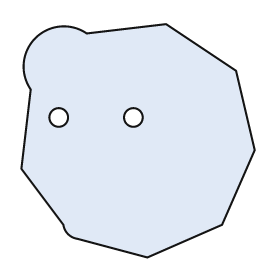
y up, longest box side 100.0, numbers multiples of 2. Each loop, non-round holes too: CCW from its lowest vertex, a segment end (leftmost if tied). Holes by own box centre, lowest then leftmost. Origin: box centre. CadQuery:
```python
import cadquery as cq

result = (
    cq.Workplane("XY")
    .moveTo(4.0, -50.0)
    .lineTo(36.0, -36.0)
    .lineTo(50.0, -4.0)
    .lineTo(42.0, 30.0)
    .lineTo(12.0, 50.0)
    .lineTo(-22.0, 46.0)
    .threePointArc((-44.0, 44.0), (-46.0, 22.0))
    .lineTo(-50.0, -12.0)
    .lineTo(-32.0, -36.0)
    .threePointArc((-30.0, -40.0), (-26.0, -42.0))
    .close()
    .moveTo(-34.0, 10.0)
    .circle(4.0)
    .moveTo(-2.0, 10.0)
    .circle(4.0)
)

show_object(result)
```